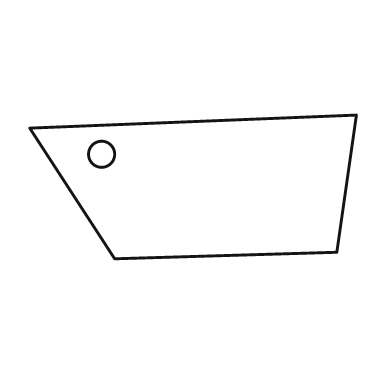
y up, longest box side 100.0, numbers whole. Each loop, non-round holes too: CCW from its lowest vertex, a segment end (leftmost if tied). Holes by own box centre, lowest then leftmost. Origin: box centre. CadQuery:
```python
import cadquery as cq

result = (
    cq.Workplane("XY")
    .moveTo(-24.0, -22.0)
    .lineTo(44.0, -20.0)
    .lineTo(50.0, 22.0)
    .lineTo(-50.0, 18.0)
    .close()
    .moveTo(-28.0, 10.0)
    .circle(4.0)
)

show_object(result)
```